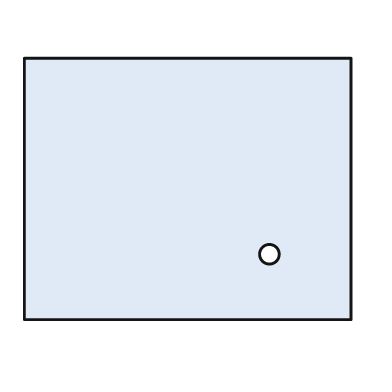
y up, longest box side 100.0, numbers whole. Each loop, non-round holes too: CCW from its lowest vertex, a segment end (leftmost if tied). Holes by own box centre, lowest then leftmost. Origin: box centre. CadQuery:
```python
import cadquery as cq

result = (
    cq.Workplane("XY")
    .moveTo(-50.0, -40.0)
    .lineTo(50.0, -40.0)
    .lineTo(50.0, 40.0)
    .lineTo(-50.0, 40.0)
    .close()
    .moveTo(25.0, -20.0)
    .circle(3.0)
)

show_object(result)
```